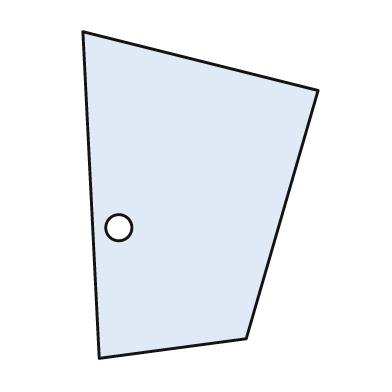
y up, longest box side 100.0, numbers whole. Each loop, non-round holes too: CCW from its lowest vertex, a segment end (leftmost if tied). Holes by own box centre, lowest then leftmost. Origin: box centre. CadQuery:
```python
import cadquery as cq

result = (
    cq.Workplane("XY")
    .moveTo(-31.0, -50.0)
    .lineTo(14.0, -44.0)
    .lineTo(36.0, 32.0)
    .lineTo(-36.0, 50.0)
    .close()
    .moveTo(-25.0, -10.0)
    .circle(4.0)
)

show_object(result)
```